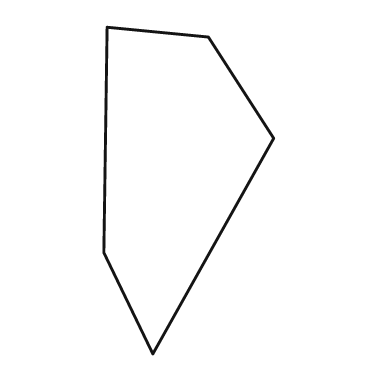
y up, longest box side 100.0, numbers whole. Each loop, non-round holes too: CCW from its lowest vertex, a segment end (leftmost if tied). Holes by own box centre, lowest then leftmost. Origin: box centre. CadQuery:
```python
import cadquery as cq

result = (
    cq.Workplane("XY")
    .moveTo(-11.0, -50.0)
    .lineTo(26.0, 16.0)
    .lineTo(6.0, 47.0)
    .lineTo(-25.0, 50.0)
    .lineTo(-26.0, -19.0)
    .close()
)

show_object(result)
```